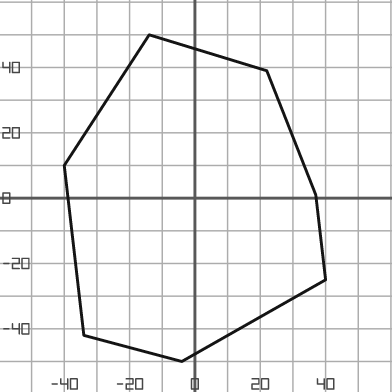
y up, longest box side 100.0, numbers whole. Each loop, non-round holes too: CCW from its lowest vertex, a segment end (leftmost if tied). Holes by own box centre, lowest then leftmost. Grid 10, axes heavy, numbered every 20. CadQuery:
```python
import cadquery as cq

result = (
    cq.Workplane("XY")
    .moveTo(-4.0, -50.0)
    .lineTo(40.0, -25.0)
    .lineTo(37.0, 1.0)
    .lineTo(22.0, 39.0)
    .lineTo(-14.0, 50.0)
    .lineTo(-40.0, 10.0)
    .lineTo(-34.0, -42.0)
    .close()
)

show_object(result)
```